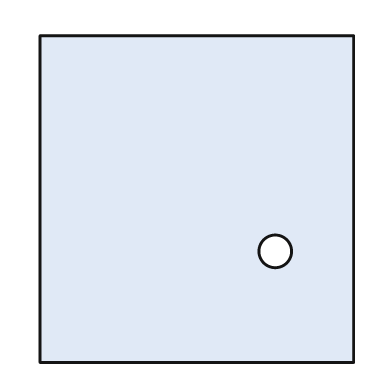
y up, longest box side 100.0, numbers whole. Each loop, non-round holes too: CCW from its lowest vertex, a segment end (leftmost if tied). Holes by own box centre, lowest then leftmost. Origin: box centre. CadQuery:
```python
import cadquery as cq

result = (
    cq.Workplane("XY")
    .moveTo(-48.0, -50.0)
    .lineTo(48.0, -50.0)
    .lineTo(48.0, 50.0)
    .lineTo(-48.0, 50.0)
    .close()
    .moveTo(24.0, -16.0)
    .circle(5.0)
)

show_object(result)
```